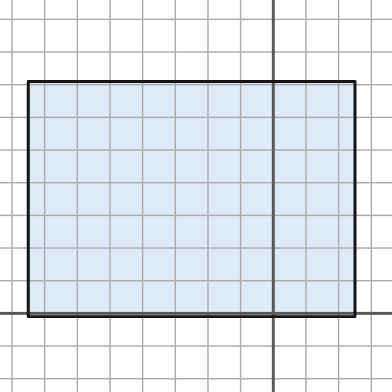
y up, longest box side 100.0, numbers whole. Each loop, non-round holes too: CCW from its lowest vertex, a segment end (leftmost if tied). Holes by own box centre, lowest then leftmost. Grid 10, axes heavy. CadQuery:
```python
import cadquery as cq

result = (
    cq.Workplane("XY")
    .moveTo(-75.0, -1.0)
    .lineTo(25.0, -1.0)
    .lineTo(25.0, 71.0)
    .lineTo(-75.0, 71.0)
    .close()
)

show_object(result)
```